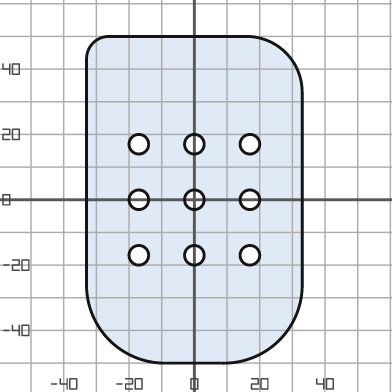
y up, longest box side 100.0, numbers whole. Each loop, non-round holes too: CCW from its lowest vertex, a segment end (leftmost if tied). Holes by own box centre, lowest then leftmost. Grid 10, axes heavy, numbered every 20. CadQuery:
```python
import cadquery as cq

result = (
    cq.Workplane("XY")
    .moveTo(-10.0, -50.0)
    .lineTo(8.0, -50.0)
    .threePointArc((26.0, -43.0), (33.0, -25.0))
    .lineTo(33.0, 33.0)
    .threePointArc((28.0, 45.0), (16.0, 50.0))
    .lineTo(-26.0, 50.0)
    .threePointArc((-31.0, 48.0), (-33.0, 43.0))
    .lineTo(-33.0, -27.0)
    .threePointArc((-26.0, -43.0), (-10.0, -50.0))
    .close()
    .moveTo(-17.0, -17.0)
    .circle(3.0)
    .moveTo(0.0, -17.0)
    .circle(3.0)
    .moveTo(17.0, -17.0)
    .circle(3.0)
    .moveTo(-17.0, 0.0)
    .circle(3.0)
    .moveTo(0.0, 0.0)
    .circle(3.0)
    .moveTo(17.0, 0.0)
    .circle(3.0)
    .moveTo(-17.0, 17.0)
    .circle(3.0)
    .moveTo(0.0, 17.0)
    .circle(3.0)
    .moveTo(17.0, 17.0)
    .circle(3.0)
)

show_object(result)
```